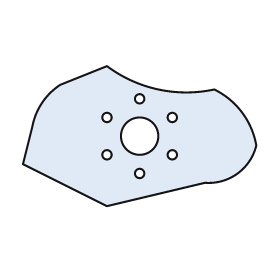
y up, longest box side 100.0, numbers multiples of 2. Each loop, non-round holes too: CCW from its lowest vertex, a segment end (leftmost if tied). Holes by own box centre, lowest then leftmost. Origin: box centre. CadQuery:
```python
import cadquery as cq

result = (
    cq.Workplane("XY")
    .moveTo(-14.0, -30.0)
    .lineTo(28.0, -20.0)
    .threePointArc((42.0, -16.0), (50.0, -4.0))
    .threePointArc((44.0, 10.0), (32.0, 20.0))
    .threePointArc((8.0, 20.0), (-14.0, 30.0))
    .lineTo(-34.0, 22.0)
    .threePointArc((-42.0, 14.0), (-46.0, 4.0))
    .lineTo(-50.0, -12.0)
    .close()
    .moveTo(0.0, -16.0)
    .circle(2.0)
    .moveTo(-14.0, -8.0)
    .circle(2.0)
    .moveTo(14.0, -8.0)
    .circle(2.0)
    .moveTo(0.0, 0.0)
    .circle(8.0)
    .moveTo(-14.0, 8.0)
    .circle(2.0)
    .moveTo(14.0, 8.0)
    .circle(2.0)
    .moveTo(0.0, 16.0)
    .circle(2.0)
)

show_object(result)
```